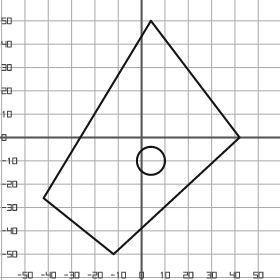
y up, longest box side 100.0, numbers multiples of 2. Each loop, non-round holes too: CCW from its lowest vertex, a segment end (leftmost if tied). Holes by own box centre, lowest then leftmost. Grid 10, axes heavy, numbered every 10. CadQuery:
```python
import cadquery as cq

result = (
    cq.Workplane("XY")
    .moveTo(-12.0, -50.0)
    .lineTo(42.0, 0.0)
    .lineTo(4.0, 50.0)
    .lineTo(-42.0, -26.0)
    .close()
    .moveTo(4.0, -10.0)
    .circle(6.0)
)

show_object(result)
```